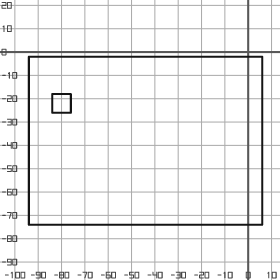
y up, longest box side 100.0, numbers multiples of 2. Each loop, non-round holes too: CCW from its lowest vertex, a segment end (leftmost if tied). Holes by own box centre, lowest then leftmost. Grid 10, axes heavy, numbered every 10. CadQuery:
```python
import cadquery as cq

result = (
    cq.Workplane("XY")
    .moveTo(-94.0, -74.0)
    .lineTo(6.0, -74.0)
    .lineTo(6.0, -2.0)
    .lineTo(-94.0, -2.0)
    .close()
    .moveTo(-84.0, -26.0)
    .lineTo(-76.0, -26.0)
    .lineTo(-76.0, -18.0)
    .lineTo(-84.0, -18.0)
    .close()
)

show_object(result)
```